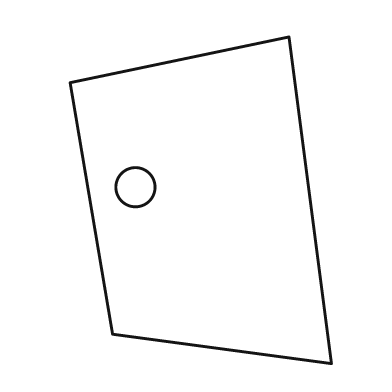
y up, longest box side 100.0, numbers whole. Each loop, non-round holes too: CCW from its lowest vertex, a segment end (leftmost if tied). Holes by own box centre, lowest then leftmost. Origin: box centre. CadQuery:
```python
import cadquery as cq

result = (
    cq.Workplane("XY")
    .moveTo(40.0, -50.0)
    .lineTo(27.0, 50.0)
    .lineTo(-40.0, 36.0)
    .lineTo(-27.0, -41.0)
    .close()
    .moveTo(-20.0, 4.0)
    .circle(6.0)
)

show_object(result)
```